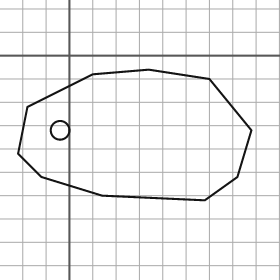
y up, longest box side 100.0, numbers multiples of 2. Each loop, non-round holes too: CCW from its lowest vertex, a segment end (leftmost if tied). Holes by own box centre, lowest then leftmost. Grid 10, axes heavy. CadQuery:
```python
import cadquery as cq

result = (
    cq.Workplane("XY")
    .moveTo(58.0, -62.0)
    .lineTo(72.0, -52.0)
    .lineTo(78.0, -32.0)
    .lineTo(60.0, -10.0)
    .lineTo(34.0, -6.0)
    .lineTo(10.0, -8.0)
    .lineTo(-18.0, -22.0)
    .lineTo(-22.0, -42.0)
    .lineTo(-12.0, -52.0)
    .lineTo(14.0, -60.0)
    .close()
    .moveTo(-4.0, -32.0)
    .circle(4.0)
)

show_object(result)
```